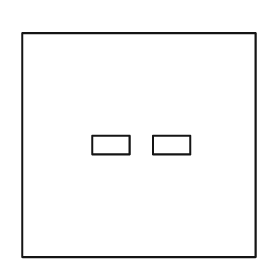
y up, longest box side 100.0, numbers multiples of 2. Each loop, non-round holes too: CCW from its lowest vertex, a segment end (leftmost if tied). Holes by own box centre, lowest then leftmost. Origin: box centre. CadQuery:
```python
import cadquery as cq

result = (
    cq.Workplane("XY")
    .moveTo(-50.0, -48.0)
    .lineTo(50.0, -48.0)
    .lineTo(50.0, 48.0)
    .lineTo(-50.0, 48.0)
    .close()
    .moveTo(-20.0, -4.0)
    .lineTo(-4.0, -4.0)
    .lineTo(-4.0, 4.0)
    .lineTo(-20.0, 4.0)
    .close()
    .moveTo(6.0, -4.0)
    .lineTo(22.0, -4.0)
    .lineTo(22.0, 4.0)
    .lineTo(6.0, 4.0)
    .close()
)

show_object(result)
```